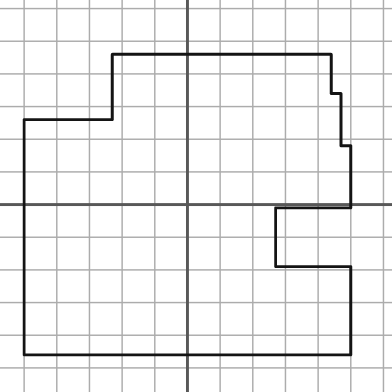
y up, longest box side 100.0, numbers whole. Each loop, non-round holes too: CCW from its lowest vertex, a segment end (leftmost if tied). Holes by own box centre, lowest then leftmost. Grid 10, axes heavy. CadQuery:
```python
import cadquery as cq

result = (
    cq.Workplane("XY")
    .moveTo(-50.0, -46.0)
    .lineTo(50.0, -46.0)
    .lineTo(50.0, -19.0)
    .lineTo(27.0, -19.0)
    .lineTo(27.0, -1.0)
    .lineTo(50.0, -1.0)
    .lineTo(50.0, 18.0)
    .lineTo(47.0, 18.0)
    .lineTo(47.0, 34.0)
    .lineTo(44.0, 34.0)
    .lineTo(44.0, 46.0)
    .lineTo(-23.0, 46.0)
    .lineTo(-23.0, 26.0)
    .lineTo(-50.0, 26.0)
    .close()
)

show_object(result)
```